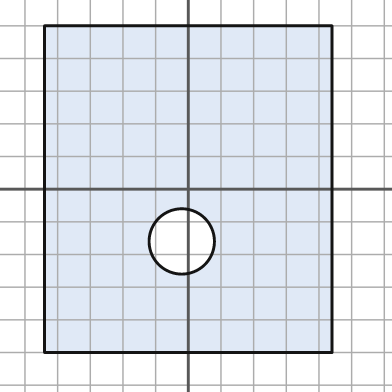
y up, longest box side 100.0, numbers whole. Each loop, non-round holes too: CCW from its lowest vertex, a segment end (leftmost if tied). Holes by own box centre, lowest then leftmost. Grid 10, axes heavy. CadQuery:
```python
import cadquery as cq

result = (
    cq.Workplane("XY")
    .moveTo(-44.0, -50.0)
    .lineTo(44.0, -50.0)
    .lineTo(44.0, 50.0)
    .lineTo(-44.0, 50.0)
    .close()
    .moveTo(-2.0, -16.0)
    .circle(10.0)
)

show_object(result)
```